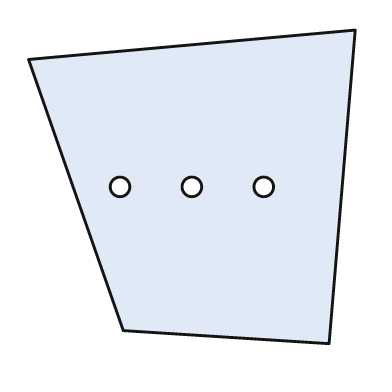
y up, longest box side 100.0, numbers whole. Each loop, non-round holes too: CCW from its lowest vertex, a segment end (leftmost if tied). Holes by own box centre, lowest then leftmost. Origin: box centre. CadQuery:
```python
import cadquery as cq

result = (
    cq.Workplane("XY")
    .moveTo(42.0, -48.0)
    .lineTo(50.0, 48.0)
    .lineTo(-50.0, 39.0)
    .lineTo(-21.0, -44.0)
    .close()
    .moveTo(-22.0, 0.0)
    .circle(3.0)
    .moveTo(0.0, 0.0)
    .circle(3.0)
    .moveTo(22.0, 0.0)
    .circle(3.0)
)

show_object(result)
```